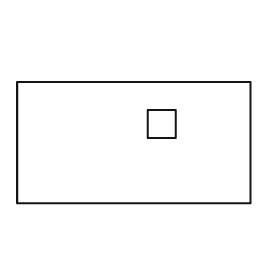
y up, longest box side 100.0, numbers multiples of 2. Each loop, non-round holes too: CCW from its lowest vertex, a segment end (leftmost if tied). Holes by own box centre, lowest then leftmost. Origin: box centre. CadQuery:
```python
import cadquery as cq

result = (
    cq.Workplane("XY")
    .moveTo(-50.0, -26.0)
    .lineTo(50.0, -26.0)
    .lineTo(50.0, 26.0)
    .lineTo(-50.0, 26.0)
    .close()
    .moveTo(6.0, 2.0)
    .lineTo(18.0, 2.0)
    .lineTo(18.0, 14.0)
    .lineTo(6.0, 14.0)
    .close()
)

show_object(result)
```